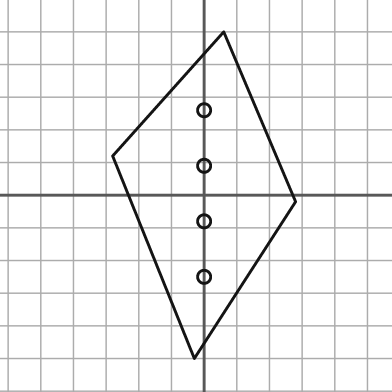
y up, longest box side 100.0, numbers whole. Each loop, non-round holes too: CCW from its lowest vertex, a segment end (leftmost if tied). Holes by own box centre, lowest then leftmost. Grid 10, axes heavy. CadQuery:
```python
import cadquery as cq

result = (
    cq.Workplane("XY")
    .moveTo(-3.0, -50.0)
    .lineTo(28.0, -2.0)
    .lineTo(6.0, 50.0)
    .lineTo(-28.0, 12.0)
    .close()
    .moveTo(0.0, -25.0)
    .circle(2.0)
    .moveTo(0.0, -8.0)
    .circle(2.0)
    .moveTo(0.0, 9.0)
    .circle(2.0)
    .moveTo(0.0, 26.0)
    .circle(2.0)
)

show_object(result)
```